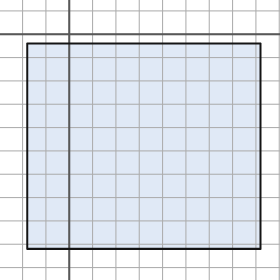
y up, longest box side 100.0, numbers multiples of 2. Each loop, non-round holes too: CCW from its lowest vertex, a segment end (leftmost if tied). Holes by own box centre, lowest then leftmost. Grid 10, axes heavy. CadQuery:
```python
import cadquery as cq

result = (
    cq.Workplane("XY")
    .moveTo(-18.0, -92.0)
    .lineTo(82.0, -92.0)
    .lineTo(82.0, -4.0)
    .lineTo(-18.0, -4.0)
    .close()
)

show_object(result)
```